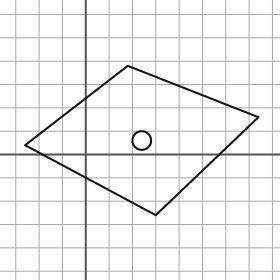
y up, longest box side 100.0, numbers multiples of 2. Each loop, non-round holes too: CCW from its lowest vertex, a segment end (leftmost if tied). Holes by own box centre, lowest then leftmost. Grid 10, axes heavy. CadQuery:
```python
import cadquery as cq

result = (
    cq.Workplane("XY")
    .moveTo(30.0, -26.0)
    .lineTo(74.0, 16.0)
    .lineTo(18.0, 38.0)
    .lineTo(-26.0, 4.0)
    .close()
    .moveTo(24.0, 6.0)
    .circle(4.0)
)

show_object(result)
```